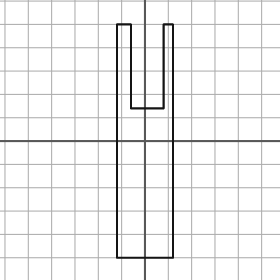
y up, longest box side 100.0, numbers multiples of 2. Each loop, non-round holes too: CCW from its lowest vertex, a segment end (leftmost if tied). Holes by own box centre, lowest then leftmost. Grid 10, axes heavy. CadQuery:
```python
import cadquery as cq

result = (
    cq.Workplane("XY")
    .moveTo(-12.0, -50.0)
    .lineTo(12.0, -50.0)
    .lineTo(12.0, 50.0)
    .lineTo(8.0, 50.0)
    .lineTo(8.0, 14.0)
    .lineTo(-6.0, 14.0)
    .lineTo(-6.0, 50.0)
    .lineTo(-12.0, 50.0)
    .close()
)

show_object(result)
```